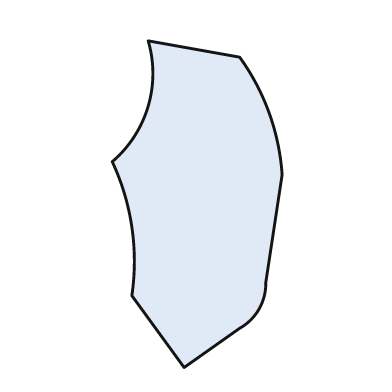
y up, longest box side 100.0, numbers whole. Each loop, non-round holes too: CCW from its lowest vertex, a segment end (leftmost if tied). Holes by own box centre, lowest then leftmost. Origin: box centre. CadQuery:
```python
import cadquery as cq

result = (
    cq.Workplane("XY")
    .moveTo(-4.0, -50.0)
    .lineTo(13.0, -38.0)
    .threePointArc((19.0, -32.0), (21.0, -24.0))
    .lineTo(26.0, 9.0)
    .threePointArc((22.0, 28.0), (13.0, 45.0))
    .lineTo(-15.0, 50.0)
    .threePointArc((-15.0, 30.0), (-26.0, 13.0))
    .threePointArc((-20.0, -7.0), (-20.0, -28.0))
    .close()
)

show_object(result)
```